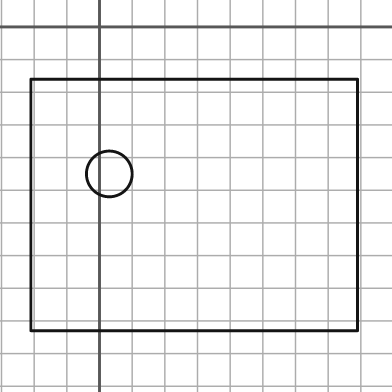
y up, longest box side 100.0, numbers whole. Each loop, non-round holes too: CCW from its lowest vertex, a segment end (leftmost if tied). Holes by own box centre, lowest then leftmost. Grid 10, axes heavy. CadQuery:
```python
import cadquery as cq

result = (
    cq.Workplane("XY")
    .moveTo(-21.0, -93.0)
    .lineTo(79.0, -93.0)
    .lineTo(79.0, -16.0)
    .lineTo(-21.0, -16.0)
    .close()
    .moveTo(3.0, -45.0)
    .circle(7.0)
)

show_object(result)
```